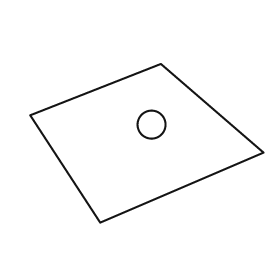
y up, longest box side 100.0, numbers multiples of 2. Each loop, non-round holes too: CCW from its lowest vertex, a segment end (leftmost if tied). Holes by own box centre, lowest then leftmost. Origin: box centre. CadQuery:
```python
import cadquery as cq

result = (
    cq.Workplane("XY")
    .moveTo(-20.0, -34.0)
    .lineTo(50.0, -4.0)
    .lineTo(6.0, 34.0)
    .lineTo(-50.0, 12.0)
    .close()
    .moveTo(2.0, 8.0)
    .circle(6.0)
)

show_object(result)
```